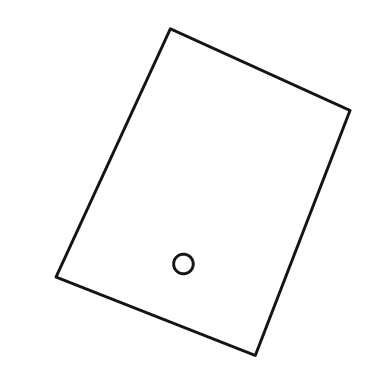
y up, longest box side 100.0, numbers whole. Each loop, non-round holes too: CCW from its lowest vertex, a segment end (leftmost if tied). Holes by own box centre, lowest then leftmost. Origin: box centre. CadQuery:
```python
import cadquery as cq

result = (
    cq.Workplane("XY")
    .moveTo(16.0, -50.0)
    .lineTo(45.0, 25.0)
    .lineTo(-10.0, 50.0)
    .lineTo(-45.0, -26.0)
    .close()
    .moveTo(-6.0, -22.0)
    .circle(3.0)
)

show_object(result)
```